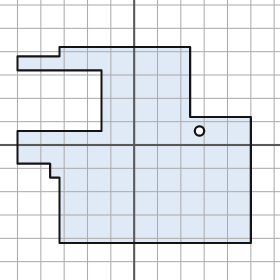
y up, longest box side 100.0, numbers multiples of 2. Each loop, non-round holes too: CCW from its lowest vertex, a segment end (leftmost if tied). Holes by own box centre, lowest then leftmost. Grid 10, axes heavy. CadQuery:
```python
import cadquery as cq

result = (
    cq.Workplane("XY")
    .moveTo(-32.0, -42.0)
    .lineTo(50.0, -42.0)
    .lineTo(50.0, 12.0)
    .lineTo(24.0, 12.0)
    .lineTo(24.0, 42.0)
    .lineTo(-32.0, 42.0)
    .lineTo(-32.0, 38.0)
    .lineTo(-50.0, 38.0)
    .lineTo(-50.0, 32.0)
    .lineTo(-14.0, 32.0)
    .lineTo(-14.0, 6.0)
    .lineTo(-50.0, 6.0)
    .lineTo(-50.0, -8.0)
    .lineTo(-36.0, -8.0)
    .lineTo(-36.0, -14.0)
    .lineTo(-32.0, -14.0)
    .close()
    .moveTo(28.0, 6.0)
    .circle(2.0)
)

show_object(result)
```